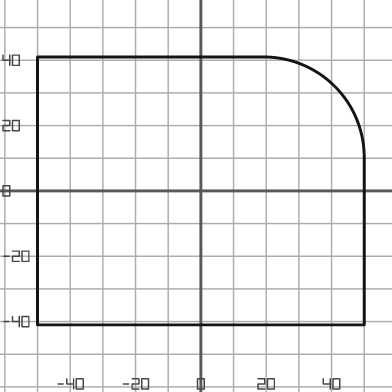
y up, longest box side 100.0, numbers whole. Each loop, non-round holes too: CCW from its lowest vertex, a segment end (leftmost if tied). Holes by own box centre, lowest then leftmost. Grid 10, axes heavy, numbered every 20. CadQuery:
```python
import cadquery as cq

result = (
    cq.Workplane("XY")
    .moveTo(-50.0, -41.0)
    .lineTo(50.0, -41.0)
    .lineTo(50.0, 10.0)
    .threePointArc((41.0, 32.0), (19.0, 41.0))
    .lineTo(-50.0, 41.0)
    .close()
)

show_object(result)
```